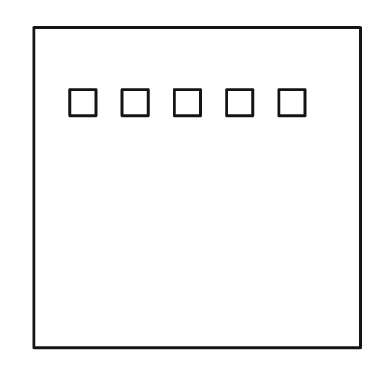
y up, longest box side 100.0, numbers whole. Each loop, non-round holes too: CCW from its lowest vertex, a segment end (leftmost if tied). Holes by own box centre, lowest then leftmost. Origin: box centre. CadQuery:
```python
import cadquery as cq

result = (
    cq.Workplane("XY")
    .moveTo(-50.0, -49.0)
    .lineTo(50.0, -49.0)
    .lineTo(50.0, 49.0)
    .lineTo(-50.0, 49.0)
    .close()
    .moveTo(-39.0, 22.0)
    .lineTo(-31.0, 22.0)
    .lineTo(-31.0, 30.0)
    .lineTo(-39.0, 30.0)
    .close()
    .moveTo(-23.0, 22.0)
    .lineTo(-15.0, 22.0)
    .lineTo(-15.0, 30.0)
    .lineTo(-23.0, 30.0)
    .close()
    .moveTo(-7.0, 22.0)
    .lineTo(1.0, 22.0)
    .lineTo(1.0, 30.0)
    .lineTo(-7.0, 30.0)
    .close()
    .moveTo(9.0, 22.0)
    .lineTo(17.0, 22.0)
    .lineTo(17.0, 30.0)
    .lineTo(9.0, 30.0)
    .close()
    .moveTo(25.0, 22.0)
    .lineTo(33.0, 22.0)
    .lineTo(33.0, 30.0)
    .lineTo(25.0, 30.0)
    .close()
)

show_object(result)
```